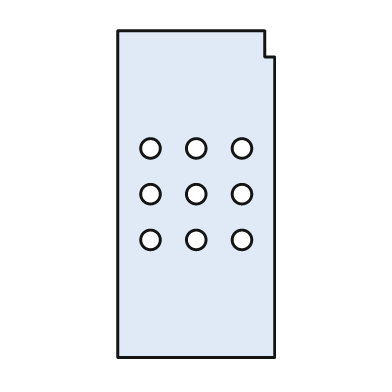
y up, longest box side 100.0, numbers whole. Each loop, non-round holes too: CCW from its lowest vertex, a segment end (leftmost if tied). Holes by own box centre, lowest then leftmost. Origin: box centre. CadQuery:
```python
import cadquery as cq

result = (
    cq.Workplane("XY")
    .moveTo(-24.0, -50.0)
    .lineTo(24.0, -50.0)
    .lineTo(24.0, 42.0)
    .lineTo(21.0, 42.0)
    .lineTo(21.0, 50.0)
    .lineTo(-24.0, 50.0)
    .close()
    .moveTo(-14.0, -14.0)
    .circle(3.0)
    .moveTo(0.0, -14.0)
    .circle(3.0)
    .moveTo(14.0, -14.0)
    .circle(3.0)
    .moveTo(-14.0, 0.0)
    .circle(3.0)
    .moveTo(0.0, 0.0)
    .circle(3.0)
    .moveTo(14.0, 0.0)
    .circle(3.0)
    .moveTo(-14.0, 14.0)
    .circle(3.0)
    .moveTo(0.0, 14.0)
    .circle(3.0)
    .moveTo(14.0, 14.0)
    .circle(3.0)
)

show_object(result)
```